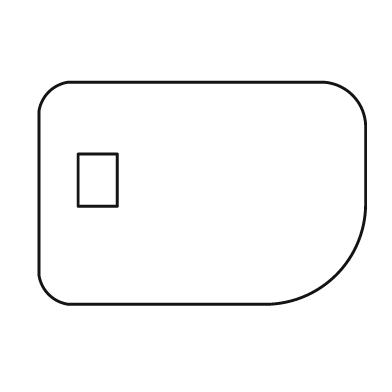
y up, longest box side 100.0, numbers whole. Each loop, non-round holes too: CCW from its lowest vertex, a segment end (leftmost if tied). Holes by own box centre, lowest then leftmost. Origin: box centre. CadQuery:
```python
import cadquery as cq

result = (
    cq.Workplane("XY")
    .moveTo(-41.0, -34.0)
    .lineTo(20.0, -34.0)
    .threePointArc((41.0, -25.0), (50.0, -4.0))
    .lineTo(50.0, 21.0)
    .threePointArc((46.0, 30.0), (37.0, 34.0))
    .lineTo(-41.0, 34.0)
    .threePointArc((-47.0, 31.0), (-50.0, 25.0))
    .lineTo(-50.0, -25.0)
    .threePointArc((-47.0, -31.0), (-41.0, -34.0))
    .close()
    .moveTo(-38.0, -4.0)
    .lineTo(-26.0, -4.0)
    .lineTo(-26.0, 12.0)
    .lineTo(-38.0, 12.0)
    .close()
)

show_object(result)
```